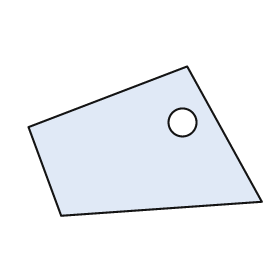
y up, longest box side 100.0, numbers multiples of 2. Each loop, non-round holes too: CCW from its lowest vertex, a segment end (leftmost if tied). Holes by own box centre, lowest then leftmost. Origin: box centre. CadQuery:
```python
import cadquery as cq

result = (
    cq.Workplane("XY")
    .moveTo(-36.0, -32.0)
    .lineTo(50.0, -26.0)
    .lineTo(18.0, 32.0)
    .lineTo(-50.0, 6.0)
    .close()
    .moveTo(16.0, 8.0)
    .circle(6.0)
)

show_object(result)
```